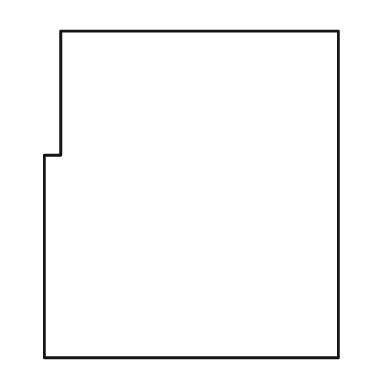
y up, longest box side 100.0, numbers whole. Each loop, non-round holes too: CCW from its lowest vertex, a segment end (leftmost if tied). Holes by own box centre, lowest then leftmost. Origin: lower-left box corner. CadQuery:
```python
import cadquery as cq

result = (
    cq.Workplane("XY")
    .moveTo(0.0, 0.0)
    .lineTo(90.0, 0.0)
    .lineTo(90.0, 100.0)
    .lineTo(5.0, 100.0)
    .lineTo(5.0, 62.0)
    .lineTo(0.0, 62.0)
    .close()
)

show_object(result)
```